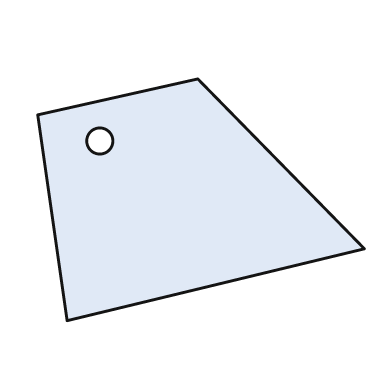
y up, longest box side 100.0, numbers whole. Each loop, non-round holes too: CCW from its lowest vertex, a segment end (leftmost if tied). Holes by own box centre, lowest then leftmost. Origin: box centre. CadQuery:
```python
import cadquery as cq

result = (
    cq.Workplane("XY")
    .moveTo(-41.0, -37.0)
    .lineTo(50.0, -15.0)
    .lineTo(-1.0, 37.0)
    .lineTo(-50.0, 26.0)
    .close()
    .moveTo(-31.0, 18.0)
    .circle(4.0)
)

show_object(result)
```